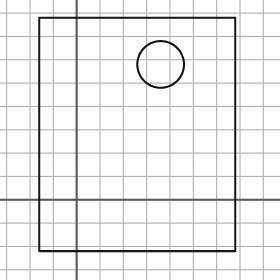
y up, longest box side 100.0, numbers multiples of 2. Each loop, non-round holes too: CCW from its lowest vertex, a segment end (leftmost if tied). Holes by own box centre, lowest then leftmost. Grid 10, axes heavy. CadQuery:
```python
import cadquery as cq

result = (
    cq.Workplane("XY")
    .moveTo(-16.0, -22.0)
    .lineTo(68.0, -22.0)
    .lineTo(68.0, 78.0)
    .lineTo(-16.0, 78.0)
    .close()
    .moveTo(36.0, 58.0)
    .circle(10.0)
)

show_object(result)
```